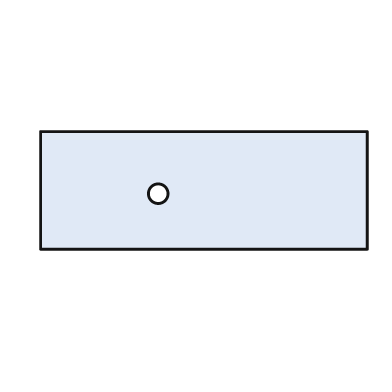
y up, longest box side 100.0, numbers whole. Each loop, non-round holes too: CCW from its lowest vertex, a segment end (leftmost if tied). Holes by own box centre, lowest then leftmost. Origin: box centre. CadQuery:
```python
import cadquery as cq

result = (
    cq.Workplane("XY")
    .moveTo(-50.0, -18.0)
    .lineTo(50.0, -18.0)
    .lineTo(50.0, 18.0)
    .lineTo(-50.0, 18.0)
    .close()
    .moveTo(-14.0, -1.0)
    .circle(3.0)
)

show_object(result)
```